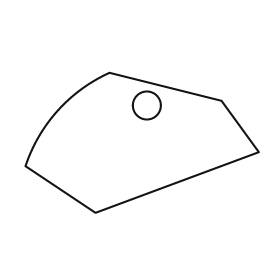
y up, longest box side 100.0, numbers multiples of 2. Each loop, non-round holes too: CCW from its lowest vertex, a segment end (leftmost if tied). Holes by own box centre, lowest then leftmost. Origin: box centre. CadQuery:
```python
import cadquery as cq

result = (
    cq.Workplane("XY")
    .moveTo(-20.0, -30.0)
    .lineTo(50.0, -4.0)
    .lineTo(34.0, 18.0)
    .lineTo(-14.0, 30.0)
    .threePointArc((-36.0, 14.0), (-50.0, -10.0))
    .close()
    .moveTo(2.0, 16.0)
    .circle(6.0)
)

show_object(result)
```